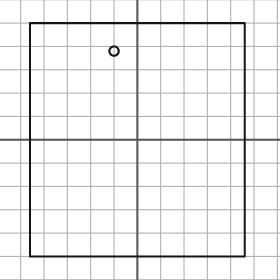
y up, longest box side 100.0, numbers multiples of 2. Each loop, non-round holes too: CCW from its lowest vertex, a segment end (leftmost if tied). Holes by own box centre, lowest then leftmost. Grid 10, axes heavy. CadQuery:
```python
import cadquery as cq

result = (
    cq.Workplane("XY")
    .moveTo(-46.0, -50.0)
    .lineTo(46.0, -50.0)
    .lineTo(46.0, 50.0)
    .lineTo(-46.0, 50.0)
    .close()
    .moveTo(-10.0, 38.0)
    .circle(2.0)
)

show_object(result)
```